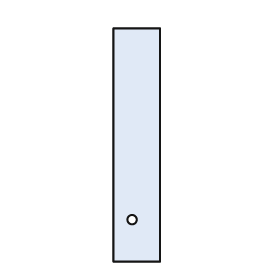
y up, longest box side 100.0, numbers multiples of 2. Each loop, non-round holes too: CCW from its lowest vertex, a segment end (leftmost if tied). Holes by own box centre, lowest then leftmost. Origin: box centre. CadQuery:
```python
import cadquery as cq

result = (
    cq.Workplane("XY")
    .moveTo(-10.0, -50.0)
    .lineTo(10.0, -50.0)
    .lineTo(10.0, 50.0)
    .lineTo(-10.0, 50.0)
    .close()
    .moveTo(-2.0, -32.0)
    .circle(2.0)
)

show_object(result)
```